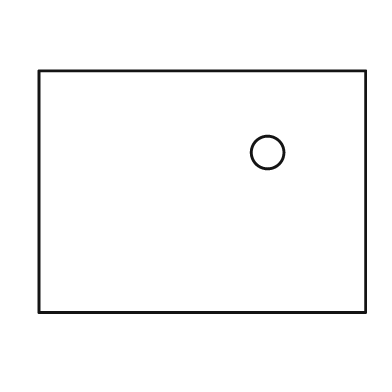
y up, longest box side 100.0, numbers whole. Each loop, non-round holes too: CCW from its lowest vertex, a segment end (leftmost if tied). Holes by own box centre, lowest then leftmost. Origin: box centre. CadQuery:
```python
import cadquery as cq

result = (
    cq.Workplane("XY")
    .moveTo(-50.0, -37.0)
    .lineTo(50.0, -37.0)
    .lineTo(50.0, 37.0)
    .lineTo(-50.0, 37.0)
    .close()
    .moveTo(20.0, 12.0)
    .circle(5.0)
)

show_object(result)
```